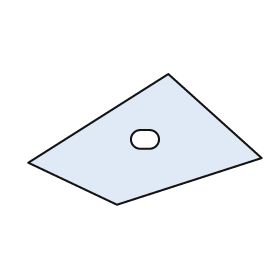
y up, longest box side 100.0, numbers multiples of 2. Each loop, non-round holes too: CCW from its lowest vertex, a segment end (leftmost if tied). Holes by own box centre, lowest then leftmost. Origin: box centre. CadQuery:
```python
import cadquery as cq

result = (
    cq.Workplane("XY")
    .moveTo(-12.0, -28.0)
    .lineTo(50.0, -8.0)
    .lineTo(10.0, 28.0)
    .lineTo(-50.0, -10.0)
    .close()
    .moveTo(-2.0, -4.0)
    .lineTo(2.0, -4.0)
    .threePointArc((6.0, 0.0), (2.0, 4.0))
    .lineTo(-2.0, 4.0)
    .threePointArc((-6.0, 0.0), (-2.0, -4.0))
    .close()
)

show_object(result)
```